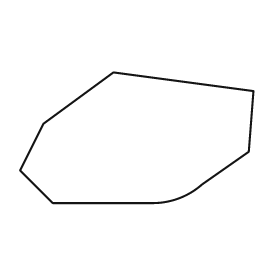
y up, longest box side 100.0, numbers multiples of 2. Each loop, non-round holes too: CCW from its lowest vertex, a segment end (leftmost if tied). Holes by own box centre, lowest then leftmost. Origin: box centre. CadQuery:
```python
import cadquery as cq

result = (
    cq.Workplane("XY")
    .moveTo(-36.0, -28.0)
    .lineTo(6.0, -28.0)
    .threePointArc((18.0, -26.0), (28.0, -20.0))
    .lineTo(48.0, -6.0)
    .lineTo(50.0, 20.0)
    .lineTo(-10.0, 28.0)
    .lineTo(-40.0, 6.0)
    .lineTo(-50.0, -14.0)
    .close()
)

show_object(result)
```